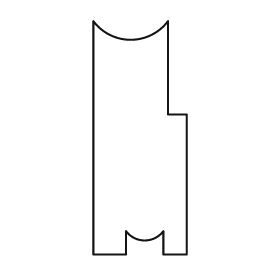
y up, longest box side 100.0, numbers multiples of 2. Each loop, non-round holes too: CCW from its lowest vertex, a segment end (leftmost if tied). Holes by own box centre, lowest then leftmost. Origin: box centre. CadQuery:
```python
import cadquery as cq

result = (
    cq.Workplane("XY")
    .moveTo(-20.0, -50.0)
    .lineTo(-6.0, -50.0)
    .lineTo(-6.0, -40.0)
    .threePointArc((2.0, -44.0), (10.0, -40.0))
    .lineTo(10.0, -50.0)
    .lineTo(20.0, -50.0)
    .lineTo(20.0, 10.0)
    .lineTo(12.0, 10.0)
    .lineTo(12.0, 50.0)
    .threePointArc((-4.0, 42.0), (-20.0, 50.0))
    .close()
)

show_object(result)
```